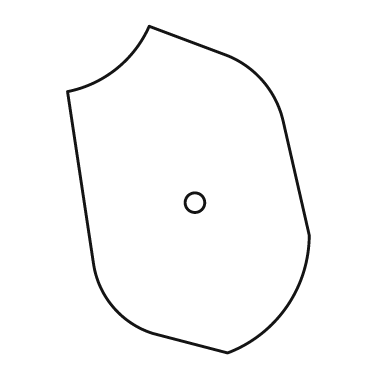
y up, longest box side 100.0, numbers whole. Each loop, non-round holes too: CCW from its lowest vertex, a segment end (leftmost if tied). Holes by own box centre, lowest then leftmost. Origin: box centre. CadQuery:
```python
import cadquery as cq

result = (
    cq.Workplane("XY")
    .moveTo(12.0, -50.0)
    .threePointArc((30.0, -36.0), (37.0, -14.0))
    .lineTo(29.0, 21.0)
    .threePointArc((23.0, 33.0), (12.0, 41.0))
    .lineTo(-12.0, 50.0)
    .threePointArc((-22.0, 37.0), (-37.0, 30.0))
    .lineTo(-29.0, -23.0)
    .threePointArc((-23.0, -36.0), (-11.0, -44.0))
    .close()
    .moveTo(2.0, -4.0)
    .circle(3.0)
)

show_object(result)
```